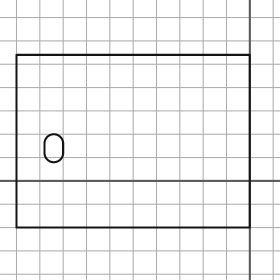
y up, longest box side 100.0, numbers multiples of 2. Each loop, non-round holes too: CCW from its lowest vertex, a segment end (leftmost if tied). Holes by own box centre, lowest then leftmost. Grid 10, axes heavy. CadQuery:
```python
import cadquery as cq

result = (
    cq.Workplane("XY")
    .moveTo(-100.0, -20.0)
    .lineTo(0.0, -20.0)
    .lineTo(0.0, 54.0)
    .lineTo(-100.0, 54.0)
    .close()
    .moveTo(-88.0, 12.0)
    .threePointArc((-84.0, 8.0), (-80.0, 12.0))
    .lineTo(-80.0, 16.0)
    .threePointArc((-84.0, 20.0), (-88.0, 16.0))
    .close()
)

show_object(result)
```